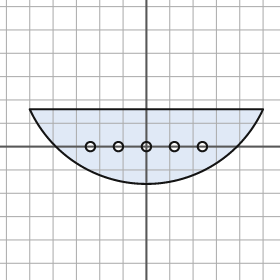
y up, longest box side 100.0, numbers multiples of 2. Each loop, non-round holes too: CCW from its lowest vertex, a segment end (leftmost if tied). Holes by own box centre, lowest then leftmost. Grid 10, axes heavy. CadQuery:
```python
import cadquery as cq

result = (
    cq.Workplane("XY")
    .moveTo(-50.0, 16.0)
    .threePointArc((0.0, -16.0), (50.0, 16.0))
    .close()
    .moveTo(-24.0, 0.0)
    .circle(2.0)
    .moveTo(-12.0, 0.0)
    .circle(2.0)
    .moveTo(0.0, 0.0)
    .circle(2.0)
    .moveTo(12.0, 0.0)
    .circle(2.0)
    .moveTo(24.0, 0.0)
    .circle(2.0)
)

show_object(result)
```